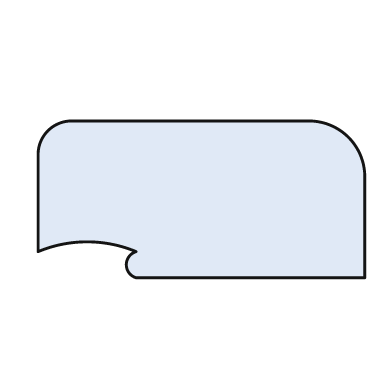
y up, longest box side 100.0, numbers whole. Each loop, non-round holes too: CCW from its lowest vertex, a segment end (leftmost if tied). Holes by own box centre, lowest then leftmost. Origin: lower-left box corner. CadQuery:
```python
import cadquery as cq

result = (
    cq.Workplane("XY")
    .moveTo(30.0, 0.0)
    .lineTo(100.0, 0.0)
    .lineTo(100.0, 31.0)
    .threePointArc((95.0, 43.0), (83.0, 48.0))
    .lineTo(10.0, 48.0)
    .threePointArc((3.0, 45.0), (0.0, 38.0))
    .lineTo(0.0, 8.0)
    .threePointArc((15.0, 11.0), (30.0, 8.0))
    .threePointArc((27.0, 4.0), (30.0, 0.0))
    .close()
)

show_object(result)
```